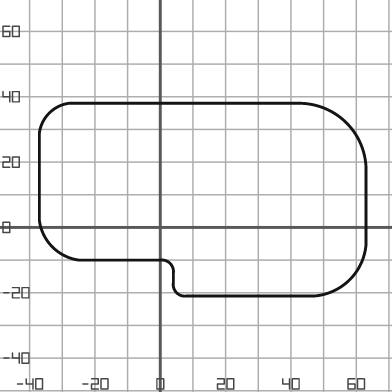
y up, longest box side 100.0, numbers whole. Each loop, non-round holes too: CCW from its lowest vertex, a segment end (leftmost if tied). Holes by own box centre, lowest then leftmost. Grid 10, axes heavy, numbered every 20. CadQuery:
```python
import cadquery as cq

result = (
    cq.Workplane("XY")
    .moveTo(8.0, -21.0)
    .lineTo(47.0, -21.0)
    .threePointArc((58.0, -16.0), (63.0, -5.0))
    .lineTo(63.0, 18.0)
    .threePointArc((57.0, 32.0), (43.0, 38.0))
    .lineTo(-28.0, 38.0)
    .threePointArc((-34.0, 35.0), (-37.0, 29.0))
    .lineTo(-37.0, 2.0)
    .threePointArc((-33.0, -6.0), (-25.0, -10.0))
    .lineTo(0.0, -10.0)
    .threePointArc((3.0, -11.0), (4.0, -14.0))
    .lineTo(4.0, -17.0)
    .threePointArc((5.0, -20.0), (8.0, -21.0))
    .close()
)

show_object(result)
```